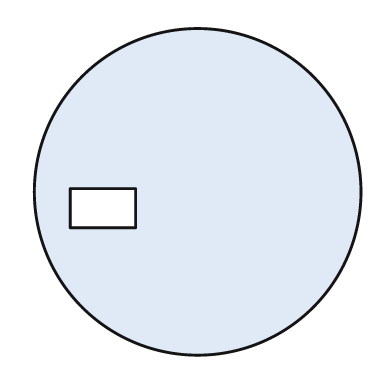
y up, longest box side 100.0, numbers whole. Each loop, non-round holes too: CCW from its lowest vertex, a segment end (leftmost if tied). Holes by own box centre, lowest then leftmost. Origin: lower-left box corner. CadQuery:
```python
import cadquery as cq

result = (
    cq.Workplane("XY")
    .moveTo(50.0, 50.0)
    .circle(50.0)
    .moveTo(11.0, 39.0)
    .lineTo(31.0, 39.0)
    .lineTo(31.0, 51.0)
    .lineTo(11.0, 51.0)
    .close()
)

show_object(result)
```